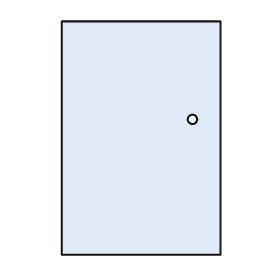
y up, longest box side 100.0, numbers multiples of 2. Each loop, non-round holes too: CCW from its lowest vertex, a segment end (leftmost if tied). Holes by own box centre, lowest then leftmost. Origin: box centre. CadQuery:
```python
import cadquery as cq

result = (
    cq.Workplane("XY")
    .moveTo(-34.0, -50.0)
    .lineTo(34.0, -50.0)
    .lineTo(34.0, 50.0)
    .lineTo(-34.0, 50.0)
    .close()
    .moveTo(22.0, 8.0)
    .circle(2.0)
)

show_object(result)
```